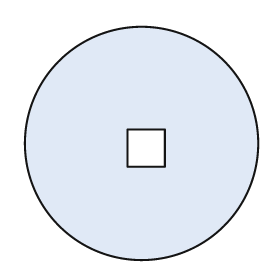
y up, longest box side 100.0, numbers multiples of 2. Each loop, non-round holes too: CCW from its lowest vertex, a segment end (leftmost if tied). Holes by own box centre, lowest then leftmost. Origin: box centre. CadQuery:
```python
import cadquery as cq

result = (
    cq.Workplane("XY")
    .moveTo(0.0, 0.0)
    .circle(50.0)
    .moveTo(-6.0, -10.0)
    .lineTo(10.0, -10.0)
    .lineTo(10.0, 6.0)
    .lineTo(-6.0, 6.0)
    .close()
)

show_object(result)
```